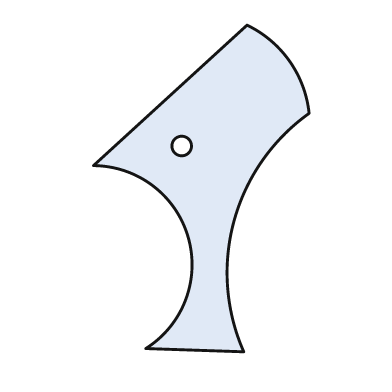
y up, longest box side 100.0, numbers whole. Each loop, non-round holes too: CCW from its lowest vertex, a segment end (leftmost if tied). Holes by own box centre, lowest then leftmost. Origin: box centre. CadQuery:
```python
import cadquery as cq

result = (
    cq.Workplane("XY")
    .moveTo(13.0, -50.0)
    .threePointArc((10.0, -10.0), (33.0, 23.0))
    .threePointArc((27.0, 39.0), (14.0, 50.0))
    .lineTo(-33.0, 7.0)
    .threePointArc((-4.0, -15.0), (-17.0, -49.0))
    .close()
    .moveTo(-6.0, 13.0)
    .circle(3.0)
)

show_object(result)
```